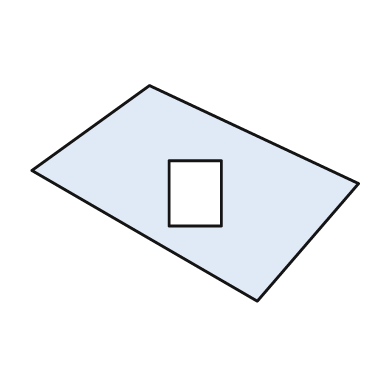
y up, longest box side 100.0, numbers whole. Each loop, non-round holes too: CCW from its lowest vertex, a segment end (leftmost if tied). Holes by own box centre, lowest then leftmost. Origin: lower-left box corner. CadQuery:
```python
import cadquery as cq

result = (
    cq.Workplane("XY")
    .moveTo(69.0, 0.0)
    .lineTo(100.0, 36.0)
    .lineTo(36.0, 66.0)
    .lineTo(0.0, 40.0)
    .close()
    .moveTo(42.0, 23.0)
    .lineTo(58.0, 23.0)
    .lineTo(58.0, 43.0)
    .lineTo(42.0, 43.0)
    .close()
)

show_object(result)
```